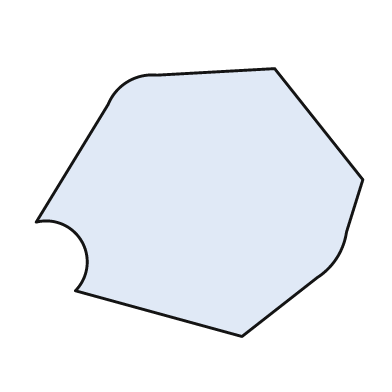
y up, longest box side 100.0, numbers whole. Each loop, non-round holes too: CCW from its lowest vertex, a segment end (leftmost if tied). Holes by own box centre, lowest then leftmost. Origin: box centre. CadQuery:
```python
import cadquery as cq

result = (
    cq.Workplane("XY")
    .moveTo(13.0, -41.0)
    .lineTo(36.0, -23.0)
    .threePointArc((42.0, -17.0), (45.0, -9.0))
    .lineTo(50.0, 7.0)
    .lineTo(23.0, 41.0)
    .lineTo(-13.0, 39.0)
    .threePointArc((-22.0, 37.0), (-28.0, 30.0))
    .lineTo(-50.0, -6.0)
    .threePointArc((-36.0, -12.0), (-38.0, -27.0))
    .close()
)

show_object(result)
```